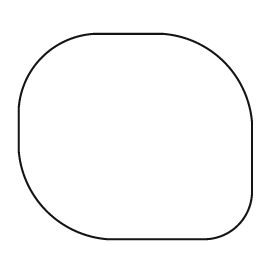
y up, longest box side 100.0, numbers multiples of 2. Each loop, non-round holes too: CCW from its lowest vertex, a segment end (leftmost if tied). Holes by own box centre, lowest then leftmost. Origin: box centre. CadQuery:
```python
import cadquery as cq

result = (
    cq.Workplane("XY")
    .moveTo(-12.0, -44.0)
    .lineTo(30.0, -44.0)
    .threePointArc((44.0, -38.0), (50.0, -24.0))
    .lineTo(50.0, 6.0)
    .threePointArc((38.0, 32.0), (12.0, 44.0))
    .lineTo(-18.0, 44.0)
    .threePointArc((-40.0, 34.0), (-50.0, 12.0))
    .lineTo(-50.0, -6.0)
    .threePointArc((-38.0, -32.0), (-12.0, -44.0))
    .close()
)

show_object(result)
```